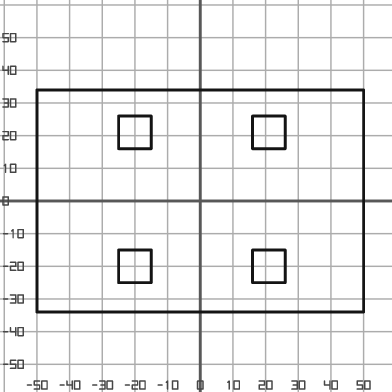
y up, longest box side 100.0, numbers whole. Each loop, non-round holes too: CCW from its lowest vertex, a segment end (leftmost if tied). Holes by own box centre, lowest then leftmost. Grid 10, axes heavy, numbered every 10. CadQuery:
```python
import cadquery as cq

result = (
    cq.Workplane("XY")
    .moveTo(-50.0, -34.0)
    .lineTo(50.0, -34.0)
    .lineTo(50.0, 34.0)
    .lineTo(-50.0, 34.0)
    .close()
    .moveTo(-25.0, -25.0)
    .lineTo(-15.0, -25.0)
    .lineTo(-15.0, -15.0)
    .lineTo(-25.0, -15.0)
    .close()
    .moveTo(16.0, -25.0)
    .lineTo(26.0, -25.0)
    .lineTo(26.0, -15.0)
    .lineTo(16.0, -15.0)
    .close()
    .moveTo(-25.0, 16.0)
    .lineTo(-15.0, 16.0)
    .lineTo(-15.0, 26.0)
    .lineTo(-25.0, 26.0)
    .close()
    .moveTo(16.0, 16.0)
    .lineTo(26.0, 16.0)
    .lineTo(26.0, 26.0)
    .lineTo(16.0, 26.0)
    .close()
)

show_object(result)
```